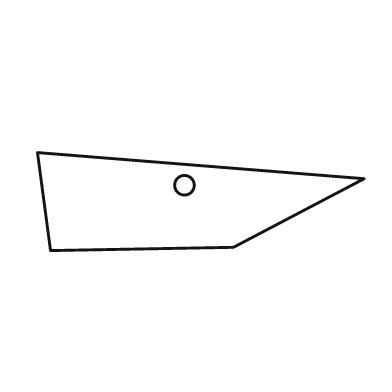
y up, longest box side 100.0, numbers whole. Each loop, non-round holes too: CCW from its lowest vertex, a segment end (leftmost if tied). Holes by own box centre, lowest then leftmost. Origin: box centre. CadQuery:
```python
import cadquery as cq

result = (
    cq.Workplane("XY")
    .moveTo(-46.0, -15.0)
    .lineTo(10.0, -14.0)
    .lineTo(50.0, 7.0)
    .lineTo(-50.0, 15.0)
    .close()
    .moveTo(-5.0, 5.0)
    .circle(3.0)
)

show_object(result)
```